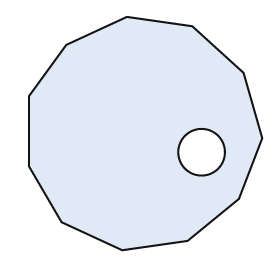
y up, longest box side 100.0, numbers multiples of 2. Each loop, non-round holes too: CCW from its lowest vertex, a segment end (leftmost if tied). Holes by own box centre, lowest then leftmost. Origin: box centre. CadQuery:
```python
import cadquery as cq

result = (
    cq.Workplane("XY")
    .moveTo(-10.0, -50.0)
    .lineTo(18.0, -46.0)
    .lineTo(40.0, -28.0)
    .lineTo(50.0, -2.0)
    .lineTo(42.0, 26.0)
    .lineTo(20.0, 46.0)
    .lineTo(-8.0, 50.0)
    .lineTo(-34.0, 38.0)
    .lineTo(-50.0, 16.0)
    .lineTo(-50.0, -14.0)
    .lineTo(-36.0, -38.0)
    .close()
    .moveTo(24.0, -8.0)
    .circle(10.0)
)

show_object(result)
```